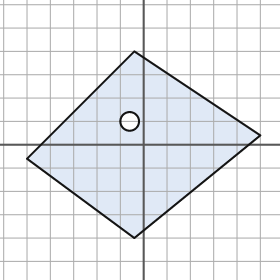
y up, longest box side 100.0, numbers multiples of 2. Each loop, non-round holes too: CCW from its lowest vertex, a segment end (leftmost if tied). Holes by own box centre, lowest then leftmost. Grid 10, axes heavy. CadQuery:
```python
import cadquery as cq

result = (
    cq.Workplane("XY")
    .moveTo(-4.0, -40.0)
    .lineTo(50.0, 4.0)
    .lineTo(-4.0, 40.0)
    .lineTo(-50.0, -6.0)
    .close()
    .moveTo(-6.0, 10.0)
    .circle(4.0)
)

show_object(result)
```